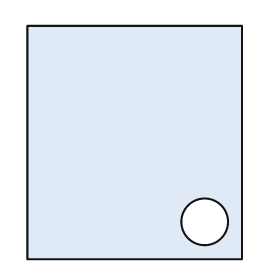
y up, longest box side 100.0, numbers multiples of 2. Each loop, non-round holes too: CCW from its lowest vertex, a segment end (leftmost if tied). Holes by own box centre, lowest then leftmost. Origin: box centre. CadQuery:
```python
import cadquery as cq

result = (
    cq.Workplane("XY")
    .moveTo(-46.0, -50.0)
    .lineTo(46.0, -50.0)
    .lineTo(46.0, 50.0)
    .lineTo(-46.0, 50.0)
    .close()
    .moveTo(30.0, -34.0)
    .circle(10.0)
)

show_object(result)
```